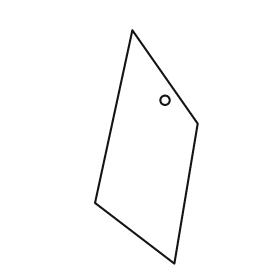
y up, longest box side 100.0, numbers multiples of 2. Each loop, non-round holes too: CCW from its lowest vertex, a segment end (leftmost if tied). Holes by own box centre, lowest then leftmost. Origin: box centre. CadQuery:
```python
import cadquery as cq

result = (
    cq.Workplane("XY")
    .moveTo(12.0, -50.0)
    .lineTo(22.0, 10.0)
    .lineTo(-6.0, 50.0)
    .lineTo(-22.0, -24.0)
    .close()
    .moveTo(8.0, 20.0)
    .circle(2.0)
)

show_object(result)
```